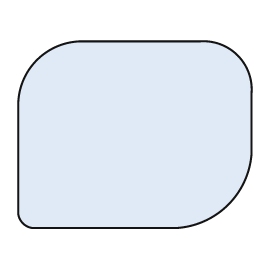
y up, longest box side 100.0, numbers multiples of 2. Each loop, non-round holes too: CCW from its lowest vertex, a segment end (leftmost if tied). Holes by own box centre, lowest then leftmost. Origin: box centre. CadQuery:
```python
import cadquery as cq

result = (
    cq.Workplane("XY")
    .moveTo(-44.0, -40.0)
    .lineTo(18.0, -40.0)
    .threePointArc((40.0, -30.0), (50.0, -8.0))
    .lineTo(50.0, 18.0)
    .threePointArc((44.0, 34.0), (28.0, 40.0))
    .lineTo(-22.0, 40.0)
    .threePointArc((-42.0, 32.0), (-50.0, 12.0))
    .lineTo(-50.0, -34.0)
    .threePointArc((-48.0, -38.0), (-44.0, -40.0))
    .close()
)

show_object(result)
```